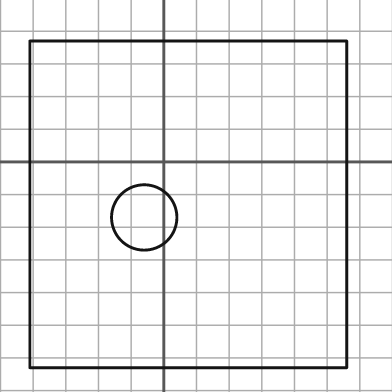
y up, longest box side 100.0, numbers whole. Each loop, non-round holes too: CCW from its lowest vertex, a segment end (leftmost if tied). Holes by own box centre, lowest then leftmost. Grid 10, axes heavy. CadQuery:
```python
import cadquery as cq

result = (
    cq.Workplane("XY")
    .moveTo(-41.0, -63.0)
    .lineTo(56.0, -63.0)
    .lineTo(56.0, 37.0)
    .lineTo(-41.0, 37.0)
    .close()
    .moveTo(-6.0, -17.0)
    .circle(10.0)
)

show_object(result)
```